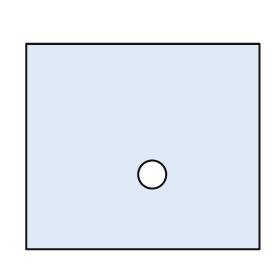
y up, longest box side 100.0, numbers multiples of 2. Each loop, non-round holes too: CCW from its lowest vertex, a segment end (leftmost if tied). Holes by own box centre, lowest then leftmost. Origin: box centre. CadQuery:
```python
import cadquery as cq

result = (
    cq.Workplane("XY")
    .moveTo(-50.0, -44.0)
    .lineTo(50.0, -44.0)
    .lineTo(50.0, 44.0)
    .lineTo(-50.0, 44.0)
    .close()
    .moveTo(4.0, -12.0)
    .circle(6.0)
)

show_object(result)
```